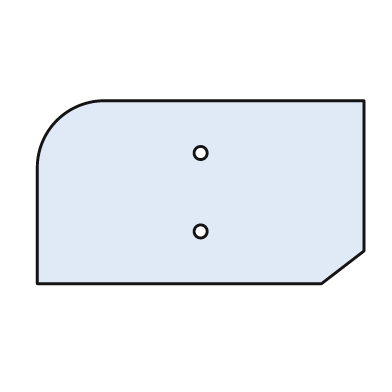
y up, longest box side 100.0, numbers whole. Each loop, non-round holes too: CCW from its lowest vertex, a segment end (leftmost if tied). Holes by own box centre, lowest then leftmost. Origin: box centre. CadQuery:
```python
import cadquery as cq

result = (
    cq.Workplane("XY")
    .moveTo(-50.0, -28.0)
    .lineTo(37.0, -28.0)
    .lineTo(50.0, -18.0)
    .lineTo(50.0, 28.0)
    .lineTo(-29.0, 28.0)
    .threePointArc((-44.0, 22.0), (-50.0, 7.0))
    .close()
    .moveTo(0.0, -12.0)
    .circle(2.0)
    .moveTo(0.0, 12.0)
    .circle(2.0)
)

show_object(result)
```